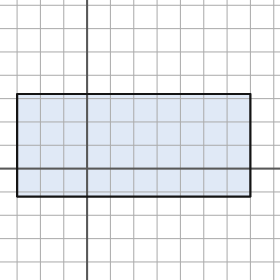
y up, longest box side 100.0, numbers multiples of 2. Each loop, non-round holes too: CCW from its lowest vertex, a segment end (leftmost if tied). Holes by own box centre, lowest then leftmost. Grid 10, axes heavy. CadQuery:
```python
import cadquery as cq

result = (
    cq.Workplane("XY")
    .moveTo(-30.0, -12.0)
    .lineTo(70.0, -12.0)
    .lineTo(70.0, 32.0)
    .lineTo(-30.0, 32.0)
    .close()
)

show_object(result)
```